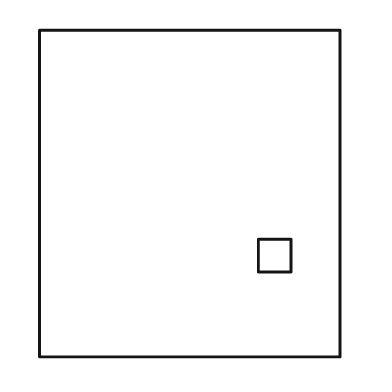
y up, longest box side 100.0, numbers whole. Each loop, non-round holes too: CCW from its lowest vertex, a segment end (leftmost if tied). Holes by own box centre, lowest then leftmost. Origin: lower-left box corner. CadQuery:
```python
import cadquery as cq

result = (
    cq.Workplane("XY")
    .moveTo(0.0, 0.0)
    .lineTo(92.0, 0.0)
    .lineTo(92.0, 100.0)
    .lineTo(0.0, 100.0)
    .close()
    .moveTo(67.0, 26.0)
    .lineTo(77.0, 26.0)
    .lineTo(77.0, 36.0)
    .lineTo(67.0, 36.0)
    .close()
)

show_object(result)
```